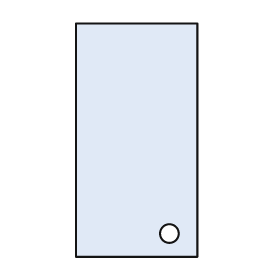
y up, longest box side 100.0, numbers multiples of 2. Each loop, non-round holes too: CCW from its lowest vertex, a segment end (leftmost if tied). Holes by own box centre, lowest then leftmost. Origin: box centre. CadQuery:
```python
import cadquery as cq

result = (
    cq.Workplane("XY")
    .moveTo(-26.0, -50.0)
    .lineTo(26.0, -50.0)
    .lineTo(26.0, 50.0)
    .lineTo(-26.0, 50.0)
    .close()
    .moveTo(14.0, -40.0)
    .circle(4.0)
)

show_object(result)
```